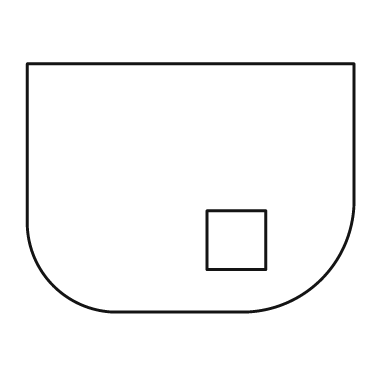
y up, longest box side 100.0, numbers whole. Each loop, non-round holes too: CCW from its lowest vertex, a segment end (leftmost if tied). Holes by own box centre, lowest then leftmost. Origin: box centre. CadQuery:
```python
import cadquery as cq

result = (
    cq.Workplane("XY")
    .moveTo(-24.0, -38.0)
    .lineTo(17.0, -38.0)
    .threePointArc((40.0, -28.0), (50.0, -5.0))
    .lineTo(50.0, 38.0)
    .lineTo(-50.0, 38.0)
    .lineTo(-50.0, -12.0)
    .threePointArc((-42.0, -30.0), (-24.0, -38.0))
    .close()
    .moveTo(5.0, -25.0)
    .lineTo(23.0, -25.0)
    .lineTo(23.0, -7.0)
    .lineTo(5.0, -7.0)
    .close()
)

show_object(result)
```